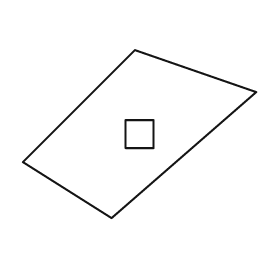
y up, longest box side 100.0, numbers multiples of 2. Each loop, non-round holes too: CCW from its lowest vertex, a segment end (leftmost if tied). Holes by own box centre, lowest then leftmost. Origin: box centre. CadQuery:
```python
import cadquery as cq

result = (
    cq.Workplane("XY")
    .moveTo(-12.0, -36.0)
    .lineTo(50.0, 18.0)
    .lineTo(-2.0, 36.0)
    .lineTo(-50.0, -12.0)
    .close()
    .moveTo(-6.0, -6.0)
    .lineTo(6.0, -6.0)
    .lineTo(6.0, 6.0)
    .lineTo(-6.0, 6.0)
    .close()
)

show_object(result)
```